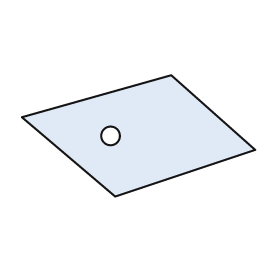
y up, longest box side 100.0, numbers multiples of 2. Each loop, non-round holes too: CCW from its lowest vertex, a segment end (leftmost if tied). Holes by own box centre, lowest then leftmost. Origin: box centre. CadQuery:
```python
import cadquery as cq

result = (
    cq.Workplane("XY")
    .moveTo(-10.0, -26.0)
    .lineTo(50.0, -6.0)
    .lineTo(14.0, 26.0)
    .lineTo(-50.0, 8.0)
    .close()
    .moveTo(-12.0, 0.0)
    .circle(4.0)
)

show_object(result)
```